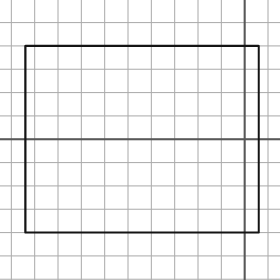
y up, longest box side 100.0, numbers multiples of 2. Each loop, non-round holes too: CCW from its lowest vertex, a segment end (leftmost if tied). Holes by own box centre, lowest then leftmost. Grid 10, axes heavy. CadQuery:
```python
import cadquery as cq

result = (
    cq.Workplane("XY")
    .moveTo(-94.0, -40.0)
    .lineTo(6.0, -40.0)
    .lineTo(6.0, 40.0)
    .lineTo(-94.0, 40.0)
    .close()
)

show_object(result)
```